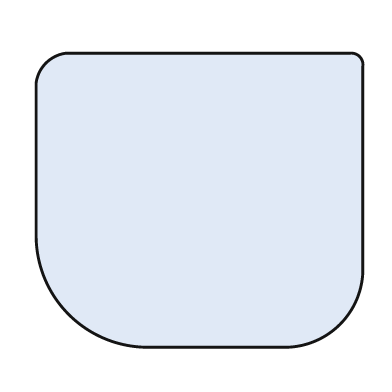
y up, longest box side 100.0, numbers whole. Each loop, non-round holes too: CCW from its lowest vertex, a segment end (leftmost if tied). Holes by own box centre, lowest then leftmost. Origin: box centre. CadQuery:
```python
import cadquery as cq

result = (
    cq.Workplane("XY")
    .moveTo(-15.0, -45.0)
    .lineTo(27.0, -45.0)
    .threePointArc((43.0, -38.0), (50.0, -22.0))
    .lineTo(50.0, 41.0)
    .threePointArc((49.0, 44.0), (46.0, 45.0))
    .lineTo(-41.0, 45.0)
    .threePointArc((-47.0, 42.0), (-50.0, 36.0))
    .lineTo(-50.0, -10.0)
    .threePointArc((-40.0, -35.0), (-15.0, -45.0))
    .close()
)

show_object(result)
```